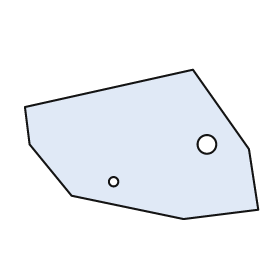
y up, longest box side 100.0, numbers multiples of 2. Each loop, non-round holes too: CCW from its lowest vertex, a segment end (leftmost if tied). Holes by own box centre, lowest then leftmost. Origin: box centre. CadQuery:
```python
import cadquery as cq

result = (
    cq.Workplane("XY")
    .moveTo(18.0, -32.0)
    .lineTo(50.0, -28.0)
    .lineTo(46.0, -2.0)
    .lineTo(22.0, 32.0)
    .lineTo(-50.0, 16.0)
    .lineTo(-48.0, 0.0)
    .lineTo(-30.0, -22.0)
    .close()
    .moveTo(-12.0, -16.0)
    .circle(2.0)
    .moveTo(28.0, 0.0)
    .circle(4.0)
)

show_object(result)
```